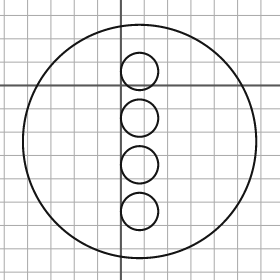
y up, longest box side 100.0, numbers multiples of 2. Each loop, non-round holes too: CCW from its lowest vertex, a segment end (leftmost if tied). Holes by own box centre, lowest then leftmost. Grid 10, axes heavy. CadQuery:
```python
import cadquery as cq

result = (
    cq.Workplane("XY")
    .moveTo(8.0, -24.0)
    .circle(50.0)
    .moveTo(8.0, -54.0)
    .circle(8.0)
    .moveTo(8.0, -34.0)
    .circle(8.0)
    .moveTo(8.0, -14.0)
    .circle(8.0)
    .moveTo(8.0, 6.0)
    .circle(8.0)
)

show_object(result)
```